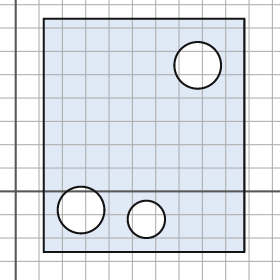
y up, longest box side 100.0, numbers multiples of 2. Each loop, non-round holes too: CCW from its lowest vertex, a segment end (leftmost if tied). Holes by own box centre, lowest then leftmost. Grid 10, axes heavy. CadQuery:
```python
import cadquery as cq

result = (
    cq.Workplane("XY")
    .moveTo(12.0, -26.0)
    .lineTo(98.0, -26.0)
    .lineTo(98.0, 74.0)
    .lineTo(12.0, 74.0)
    .close()
    .moveTo(56.0, -12.0)
    .circle(8.0)
    .moveTo(28.0, -8.0)
    .circle(10.0)
    .moveTo(78.0, 54.0)
    .circle(10.0)
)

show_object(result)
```